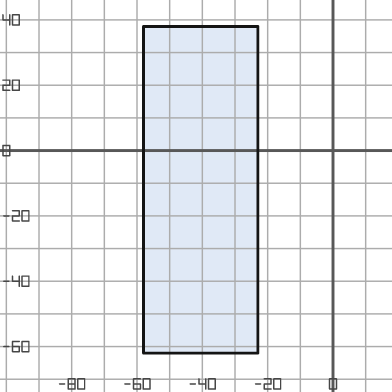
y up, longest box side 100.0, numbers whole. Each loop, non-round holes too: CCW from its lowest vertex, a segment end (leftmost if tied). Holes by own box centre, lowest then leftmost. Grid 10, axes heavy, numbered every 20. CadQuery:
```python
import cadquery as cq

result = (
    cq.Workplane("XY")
    .moveTo(-58.0, -62.0)
    .lineTo(-23.0, -62.0)
    .lineTo(-23.0, 38.0)
    .lineTo(-58.0, 38.0)
    .close()
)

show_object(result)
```